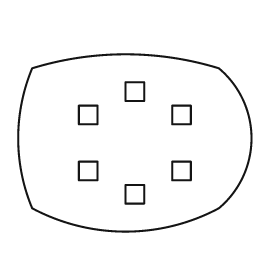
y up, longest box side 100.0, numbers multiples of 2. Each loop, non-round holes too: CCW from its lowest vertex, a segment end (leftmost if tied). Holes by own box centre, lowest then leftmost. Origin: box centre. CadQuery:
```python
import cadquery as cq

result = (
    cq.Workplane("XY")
    .moveTo(-44.0, -28.0)
    .threePointArc((-4.0, -38.0), (36.0, -28.0))
    .threePointArc((50.0, 2.0), (36.0, 32.0))
    .threePointArc((-4.0, 38.0), (-44.0, 32.0))
    .threePointArc((-50.0, 2.0), (-44.0, -28.0))
    .close()
    .moveTo(-4.0, -26.0)
    .lineTo(4.0, -26.0)
    .lineTo(4.0, -18.0)
    .lineTo(-4.0, -18.0)
    .close()
    .moveTo(-24.0, -16.0)
    .lineTo(-16.0, -16.0)
    .lineTo(-16.0, -8.0)
    .lineTo(-24.0, -8.0)
    .close()
    .moveTo(16.0, -16.0)
    .lineTo(24.0, -16.0)
    .lineTo(24.0, -8.0)
    .lineTo(16.0, -8.0)
    .close()
    .moveTo(-24.0, 8.0)
    .lineTo(-16.0, 8.0)
    .lineTo(-16.0, 16.0)
    .lineTo(-24.0, 16.0)
    .close()
    .moveTo(16.0, 8.0)
    .lineTo(24.0, 8.0)
    .lineTo(24.0, 16.0)
    .lineTo(16.0, 16.0)
    .close()
    .moveTo(-4.0, 18.0)
    .lineTo(4.0, 18.0)
    .lineTo(4.0, 26.0)
    .lineTo(-4.0, 26.0)
    .close()
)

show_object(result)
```